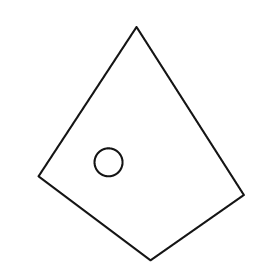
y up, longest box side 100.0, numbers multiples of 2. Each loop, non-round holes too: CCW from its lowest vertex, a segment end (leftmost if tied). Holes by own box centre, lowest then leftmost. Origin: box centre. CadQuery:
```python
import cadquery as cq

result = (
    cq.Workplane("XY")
    .moveTo(4.0, -50.0)
    .lineTo(44.0, -22.0)
    .lineTo(-2.0, 50.0)
    .lineTo(-44.0, -14.0)
    .close()
    .moveTo(-14.0, -8.0)
    .circle(6.0)
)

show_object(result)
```